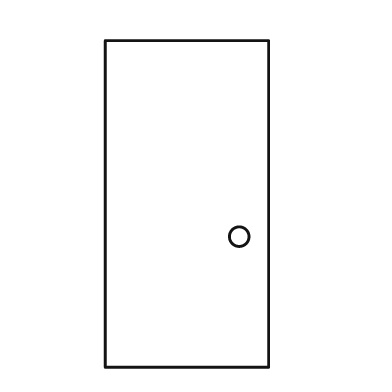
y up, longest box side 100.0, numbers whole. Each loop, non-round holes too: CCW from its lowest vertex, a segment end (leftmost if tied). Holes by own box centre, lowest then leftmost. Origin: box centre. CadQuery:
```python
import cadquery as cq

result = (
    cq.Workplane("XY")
    .moveTo(-25.0, -50.0)
    .lineTo(25.0, -50.0)
    .lineTo(25.0, 50.0)
    .lineTo(-25.0, 50.0)
    .close()
    .moveTo(16.0, -10.0)
    .circle(3.0)
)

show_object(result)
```